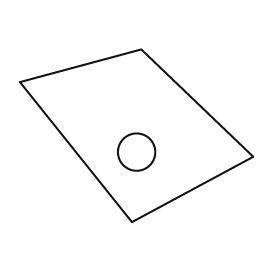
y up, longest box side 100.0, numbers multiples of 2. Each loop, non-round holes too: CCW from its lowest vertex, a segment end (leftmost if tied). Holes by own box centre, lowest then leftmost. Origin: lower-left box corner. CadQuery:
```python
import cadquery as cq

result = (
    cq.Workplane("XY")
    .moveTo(48.0, 0.0)
    .lineTo(100.0, 28.0)
    .lineTo(52.0, 74.0)
    .lineTo(0.0, 60.0)
    .close()
    .moveTo(50.0, 30.0)
    .circle(8.0)
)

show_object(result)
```